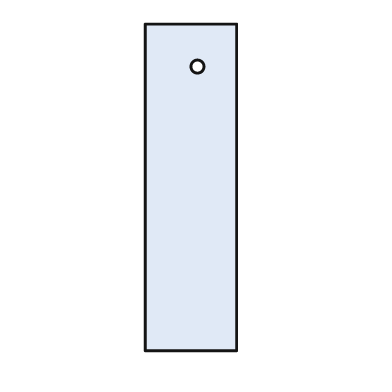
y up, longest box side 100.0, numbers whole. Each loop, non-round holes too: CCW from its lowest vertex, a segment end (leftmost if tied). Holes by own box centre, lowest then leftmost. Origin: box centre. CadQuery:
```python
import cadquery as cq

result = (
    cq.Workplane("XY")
    .moveTo(-14.0, -50.0)
    .lineTo(14.0, -50.0)
    .lineTo(14.0, 50.0)
    .lineTo(-14.0, 50.0)
    .close()
    .moveTo(2.0, 37.0)
    .circle(2.0)
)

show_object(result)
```